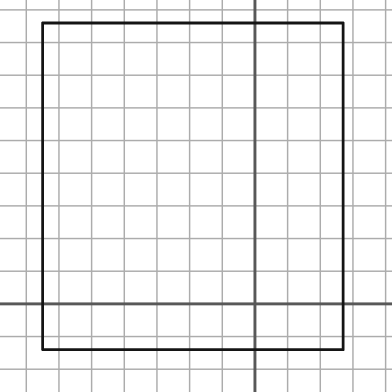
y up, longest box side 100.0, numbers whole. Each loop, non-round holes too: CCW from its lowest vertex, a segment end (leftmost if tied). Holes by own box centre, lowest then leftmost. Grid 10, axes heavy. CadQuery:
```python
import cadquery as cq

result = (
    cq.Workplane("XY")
    .moveTo(-65.0, -14.0)
    .lineTo(27.0, -14.0)
    .lineTo(27.0, 86.0)
    .lineTo(-65.0, 86.0)
    .close()
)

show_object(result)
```